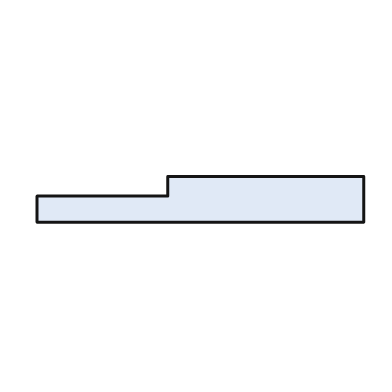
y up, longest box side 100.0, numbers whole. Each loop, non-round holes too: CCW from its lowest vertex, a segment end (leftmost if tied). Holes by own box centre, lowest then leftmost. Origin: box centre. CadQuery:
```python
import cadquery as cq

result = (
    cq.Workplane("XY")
    .moveTo(-50.0, -7.0)
    .lineTo(50.0, -7.0)
    .lineTo(50.0, 7.0)
    .lineTo(-10.0, 7.0)
    .lineTo(-10.0, 1.0)
    .lineTo(-50.0, 1.0)
    .close()
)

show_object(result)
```